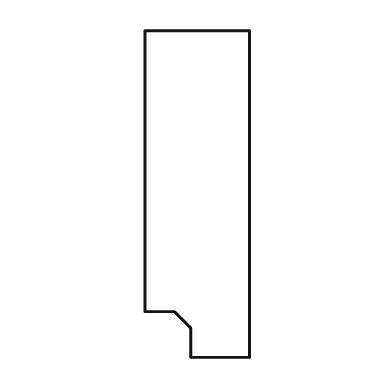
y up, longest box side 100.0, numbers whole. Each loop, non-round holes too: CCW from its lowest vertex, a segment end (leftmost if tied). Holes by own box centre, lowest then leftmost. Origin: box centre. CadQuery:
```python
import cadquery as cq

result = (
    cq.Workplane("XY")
    .moveTo(-2.0, -50.0)
    .lineTo(16.0, -50.0)
    .lineTo(16.0, 50.0)
    .lineTo(-16.0, 50.0)
    .lineTo(-16.0, -36.0)
    .lineTo(-7.0, -36.0)
    .lineTo(-2.0, -41.0)
    .close()
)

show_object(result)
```